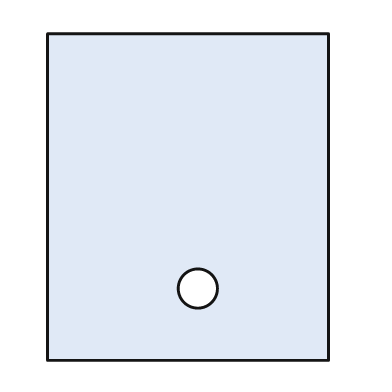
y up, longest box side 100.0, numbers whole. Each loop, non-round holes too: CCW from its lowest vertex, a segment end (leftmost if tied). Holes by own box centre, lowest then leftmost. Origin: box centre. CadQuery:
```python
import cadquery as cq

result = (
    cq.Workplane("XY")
    .moveTo(-43.0, -50.0)
    .lineTo(43.0, -50.0)
    .lineTo(43.0, 50.0)
    .lineTo(-43.0, 50.0)
    .close()
    .moveTo(3.0, -28.0)
    .circle(6.0)
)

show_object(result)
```